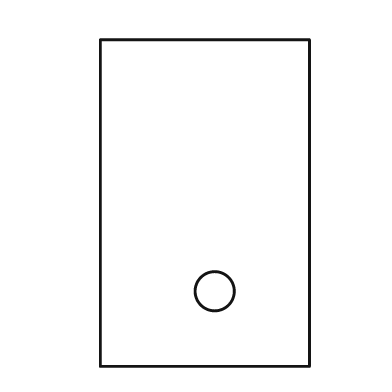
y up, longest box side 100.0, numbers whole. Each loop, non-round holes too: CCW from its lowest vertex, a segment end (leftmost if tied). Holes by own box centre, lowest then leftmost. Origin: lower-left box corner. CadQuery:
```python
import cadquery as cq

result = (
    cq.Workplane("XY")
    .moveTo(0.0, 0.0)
    .lineTo(64.0, 0.0)
    .lineTo(64.0, 100.0)
    .lineTo(0.0, 100.0)
    .close()
    .moveTo(35.0, 23.0)
    .circle(6.0)
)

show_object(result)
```